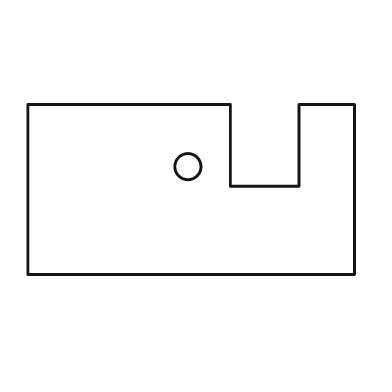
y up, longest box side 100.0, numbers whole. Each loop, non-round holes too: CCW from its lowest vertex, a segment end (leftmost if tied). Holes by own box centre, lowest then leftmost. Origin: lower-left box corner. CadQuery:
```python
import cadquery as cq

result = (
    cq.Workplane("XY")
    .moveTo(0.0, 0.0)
    .lineTo(100.0, 0.0)
    .lineTo(100.0, 52.0)
    .lineTo(83.0, 52.0)
    .lineTo(83.0, 27.0)
    .lineTo(62.0, 27.0)
    .lineTo(62.0, 52.0)
    .lineTo(0.0, 52.0)
    .close()
    .moveTo(49.0, 33.0)
    .circle(4.0)
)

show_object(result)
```